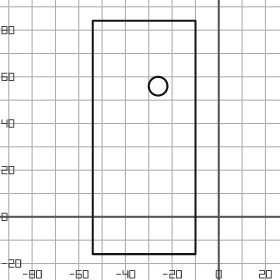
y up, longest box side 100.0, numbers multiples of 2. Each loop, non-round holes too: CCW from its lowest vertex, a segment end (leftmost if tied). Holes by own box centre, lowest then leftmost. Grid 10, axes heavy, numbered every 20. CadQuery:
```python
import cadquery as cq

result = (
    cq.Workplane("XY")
    .moveTo(-54.0, -16.0)
    .lineTo(-10.0, -16.0)
    .lineTo(-10.0, 84.0)
    .lineTo(-54.0, 84.0)
    .close()
    .moveTo(-26.0, 56.0)
    .circle(4.0)
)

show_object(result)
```